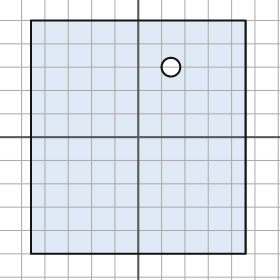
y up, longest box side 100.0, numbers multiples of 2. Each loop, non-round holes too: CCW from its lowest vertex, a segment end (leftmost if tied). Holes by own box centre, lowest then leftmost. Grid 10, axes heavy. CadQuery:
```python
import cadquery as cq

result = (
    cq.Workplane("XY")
    .moveTo(-46.0, -50.0)
    .lineTo(46.0, -50.0)
    .lineTo(46.0, 50.0)
    .lineTo(-46.0, 50.0)
    .close()
    .moveTo(14.0, 30.0)
    .circle(4.0)
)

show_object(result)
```